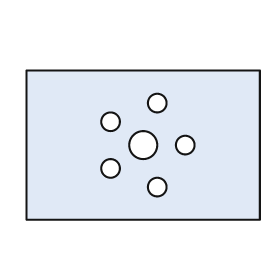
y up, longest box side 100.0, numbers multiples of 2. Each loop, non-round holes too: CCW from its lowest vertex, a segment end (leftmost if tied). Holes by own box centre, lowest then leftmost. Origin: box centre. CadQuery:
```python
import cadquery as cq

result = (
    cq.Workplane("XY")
    .moveTo(-50.0, -32.0)
    .lineTo(50.0, -32.0)
    .lineTo(50.0, 32.0)
    .lineTo(-50.0, 32.0)
    .close()
    .moveTo(6.0, -18.0)
    .circle(4.0)
    .moveTo(-14.0, -10.0)
    .circle(4.0)
    .moveTo(0.0, 0.0)
    .circle(6.0)
    .moveTo(18.0, 0.0)
    .circle(4.0)
    .moveTo(-14.0, 10.0)
    .circle(4.0)
    .moveTo(6.0, 18.0)
    .circle(4.0)
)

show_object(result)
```